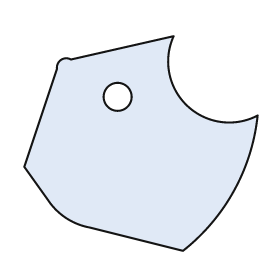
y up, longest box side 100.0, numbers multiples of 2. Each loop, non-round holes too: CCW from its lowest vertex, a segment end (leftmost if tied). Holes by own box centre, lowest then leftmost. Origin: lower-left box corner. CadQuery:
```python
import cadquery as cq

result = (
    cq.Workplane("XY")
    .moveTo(68.0, 0.0)
    .threePointArc((90.0, 26.0), (100.0, 58.0))
    .threePointArc((70.0, 62.0), (64.0, 92.0))
    .lineTo(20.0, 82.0)
    .threePointArc((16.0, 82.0), (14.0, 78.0))
    .lineTo(0.0, 36.0)
    .lineTo(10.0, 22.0)
    .threePointArc((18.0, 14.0), (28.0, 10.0))
    .close()
    .moveTo(40.0, 66.0)
    .circle(6.0)
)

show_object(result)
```